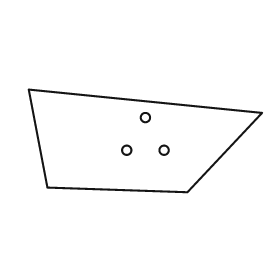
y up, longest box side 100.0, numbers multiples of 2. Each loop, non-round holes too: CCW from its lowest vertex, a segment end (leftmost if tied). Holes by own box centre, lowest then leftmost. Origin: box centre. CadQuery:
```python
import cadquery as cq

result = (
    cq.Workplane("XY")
    .moveTo(18.0, -22.0)
    .lineTo(50.0, 12.0)
    .lineTo(-50.0, 22.0)
    .lineTo(-42.0, -20.0)
    .close()
    .moveTo(-8.0, -4.0)
    .circle(2.0)
    .moveTo(8.0, -4.0)
    .circle(2.0)
    .moveTo(0.0, 10.0)
    .circle(2.0)
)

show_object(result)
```